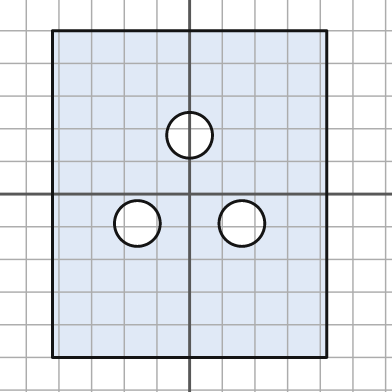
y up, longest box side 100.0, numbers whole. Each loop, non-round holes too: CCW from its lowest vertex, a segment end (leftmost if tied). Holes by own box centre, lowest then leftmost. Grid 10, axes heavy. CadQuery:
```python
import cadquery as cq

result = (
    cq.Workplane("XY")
    .moveTo(-42.0, -50.0)
    .lineTo(42.0, -50.0)
    .lineTo(42.0, 50.0)
    .lineTo(-42.0, 50.0)
    .close()
    .moveTo(-16.0, -9.0)
    .circle(7.0)
    .moveTo(16.0, -9.0)
    .circle(7.0)
    .moveTo(0.0, 18.0)
    .circle(7.0)
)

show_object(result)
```